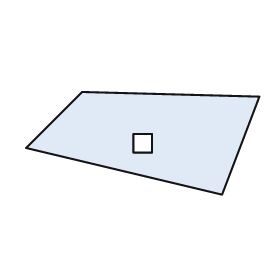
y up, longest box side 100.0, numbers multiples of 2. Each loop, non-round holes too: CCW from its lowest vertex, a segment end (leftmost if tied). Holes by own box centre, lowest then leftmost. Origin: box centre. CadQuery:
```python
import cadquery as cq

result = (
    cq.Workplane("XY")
    .moveTo(34.0, -22.0)
    .lineTo(50.0, 20.0)
    .lineTo(-26.0, 22.0)
    .lineTo(-50.0, -2.0)
    .close()
    .moveTo(-4.0, -4.0)
    .lineTo(4.0, -4.0)
    .lineTo(4.0, 4.0)
    .lineTo(-4.0, 4.0)
    .close()
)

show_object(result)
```